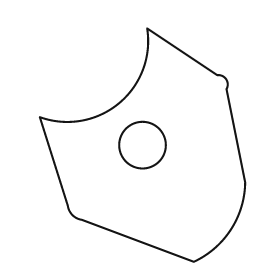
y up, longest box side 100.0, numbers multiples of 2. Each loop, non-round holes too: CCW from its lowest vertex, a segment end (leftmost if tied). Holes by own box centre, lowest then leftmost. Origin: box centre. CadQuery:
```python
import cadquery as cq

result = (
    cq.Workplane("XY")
    .moveTo(22.0, -50.0)
    .threePointArc((38.0, -36.0), (44.0, -16.0))
    .lineTo(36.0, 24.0)
    .threePointArc((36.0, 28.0), (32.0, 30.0))
    .lineTo(2.0, 50.0)
    .threePointArc((-10.0, 18.0), (-44.0, 12.0))
    .lineTo(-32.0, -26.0)
    .threePointArc((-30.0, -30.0), (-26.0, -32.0))
    .close()
    .moveTo(0.0, 0.0)
    .circle(10.0)
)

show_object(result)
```